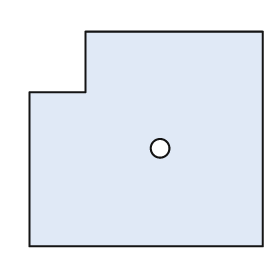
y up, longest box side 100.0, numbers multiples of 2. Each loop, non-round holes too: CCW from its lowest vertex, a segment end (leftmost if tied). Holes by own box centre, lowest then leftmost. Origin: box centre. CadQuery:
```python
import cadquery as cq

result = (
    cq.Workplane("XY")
    .moveTo(-50.0, -46.0)
    .lineTo(50.0, -46.0)
    .lineTo(50.0, 46.0)
    .lineTo(-26.0, 46.0)
    .lineTo(-26.0, 20.0)
    .lineTo(-50.0, 20.0)
    .close()
    .moveTo(6.0, -4.0)
    .circle(4.0)
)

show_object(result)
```